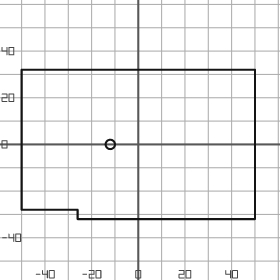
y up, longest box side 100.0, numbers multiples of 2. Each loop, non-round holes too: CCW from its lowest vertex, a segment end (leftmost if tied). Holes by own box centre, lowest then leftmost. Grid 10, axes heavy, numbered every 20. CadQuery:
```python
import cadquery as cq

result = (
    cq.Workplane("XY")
    .moveTo(-26.0, -32.0)
    .lineTo(50.0, -32.0)
    .lineTo(50.0, 32.0)
    .lineTo(-50.0, 32.0)
    .lineTo(-50.0, -28.0)
    .lineTo(-26.0, -28.0)
    .close()
    .moveTo(-12.0, 0.0)
    .circle(2.0)
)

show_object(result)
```